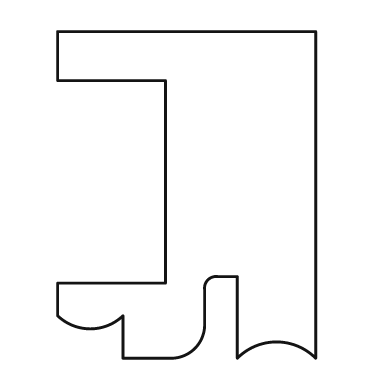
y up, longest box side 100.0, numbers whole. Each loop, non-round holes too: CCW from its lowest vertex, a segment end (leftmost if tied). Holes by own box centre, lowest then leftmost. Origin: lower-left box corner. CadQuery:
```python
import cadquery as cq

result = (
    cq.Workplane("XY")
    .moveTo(20.0, 0.0)
    .lineTo(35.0, 0.0)
    .threePointArc((42.0, 3.0), (45.0, 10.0))
    .lineTo(45.0, 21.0)
    .threePointArc((46.0, 24.0), (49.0, 25.0))
    .lineTo(55.0, 25.0)
    .lineTo(55.0, 0.0)
    .threePointArc((67.0, 5.0), (79.0, 0.0))
    .lineTo(79.0, 100.0)
    .lineTo(0.0, 100.0)
    .lineTo(0.0, 85.0)
    .lineTo(33.0, 85.0)
    .lineTo(33.0, 23.0)
    .lineTo(0.0, 23.0)
    .lineTo(0.0, 13.0)
    .threePointArc((10.0, 9.0), (20.0, 13.0))
    .close()
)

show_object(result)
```